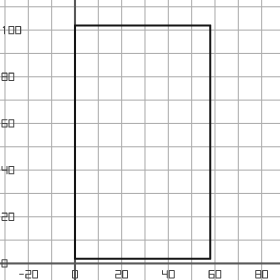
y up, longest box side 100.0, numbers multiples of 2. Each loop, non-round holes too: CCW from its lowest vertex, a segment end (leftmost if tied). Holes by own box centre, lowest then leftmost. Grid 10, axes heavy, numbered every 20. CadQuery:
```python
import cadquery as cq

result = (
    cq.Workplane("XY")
    .moveTo(0.0, 2.0)
    .lineTo(58.0, 2.0)
    .lineTo(58.0, 102.0)
    .lineTo(0.0, 102.0)
    .close()
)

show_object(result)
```